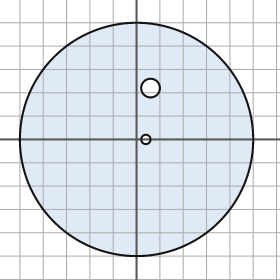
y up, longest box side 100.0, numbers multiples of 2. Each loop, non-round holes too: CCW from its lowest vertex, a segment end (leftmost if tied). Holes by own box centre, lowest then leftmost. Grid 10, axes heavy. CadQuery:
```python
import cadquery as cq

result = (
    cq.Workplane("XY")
    .moveTo(0.0, 0.0)
    .circle(50.0)
    .moveTo(4.0, 0.0)
    .circle(2.0)
    .moveTo(6.0, 22.0)
    .circle(4.0)
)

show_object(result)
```